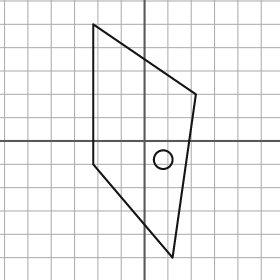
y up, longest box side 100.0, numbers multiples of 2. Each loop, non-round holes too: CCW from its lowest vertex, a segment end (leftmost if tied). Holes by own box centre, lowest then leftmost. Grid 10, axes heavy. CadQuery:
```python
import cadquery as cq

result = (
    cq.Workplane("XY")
    .moveTo(12.0, -50.0)
    .lineTo(22.0, 20.0)
    .lineTo(-22.0, 50.0)
    .lineTo(-22.0, -10.0)
    .close()
    .moveTo(8.0, -8.0)
    .circle(4.0)
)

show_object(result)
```